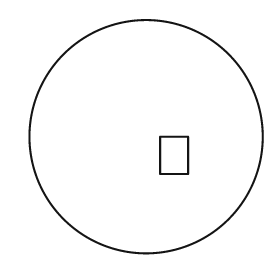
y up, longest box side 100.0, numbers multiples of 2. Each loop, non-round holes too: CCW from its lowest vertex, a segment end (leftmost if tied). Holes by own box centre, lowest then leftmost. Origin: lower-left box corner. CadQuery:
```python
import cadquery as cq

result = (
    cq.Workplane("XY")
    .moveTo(50.0, 50.0)
    .circle(50.0)
    .moveTo(56.0, 34.0)
    .lineTo(68.0, 34.0)
    .lineTo(68.0, 50.0)
    .lineTo(56.0, 50.0)
    .close()
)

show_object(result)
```